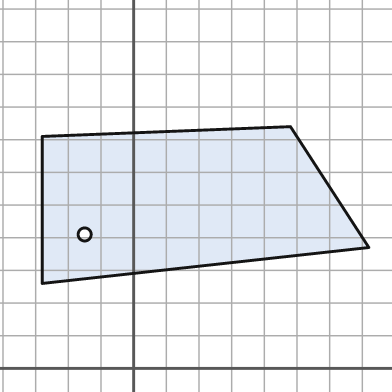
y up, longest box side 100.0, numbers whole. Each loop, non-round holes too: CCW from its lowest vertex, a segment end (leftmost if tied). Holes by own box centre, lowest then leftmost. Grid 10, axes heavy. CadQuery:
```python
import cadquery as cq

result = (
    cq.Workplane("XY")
    .moveTo(-28.0, 26.0)
    .lineTo(72.0, 37.0)
    .lineTo(48.0, 74.0)
    .lineTo(-28.0, 71.0)
    .close()
    .moveTo(-15.0, 41.0)
    .circle(2.0)
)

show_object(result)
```